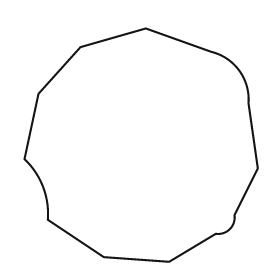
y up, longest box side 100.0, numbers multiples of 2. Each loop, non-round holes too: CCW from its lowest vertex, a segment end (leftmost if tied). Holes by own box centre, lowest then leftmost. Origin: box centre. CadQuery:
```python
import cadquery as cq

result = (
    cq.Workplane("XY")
    .moveTo(12.0, -50.0)
    .lineTo(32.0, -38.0)
    .threePointArc((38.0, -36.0), (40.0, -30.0))
    .lineTo(50.0, -10.0)
    .lineTo(46.0, 18.0)
    .threePointArc((42.0, 32.0), (30.0, 40.0))
    .lineTo(2.0, 50.0)
    .lineTo(-26.0, 42.0)
    .lineTo(-44.0, 22.0)
    .lineTo(-50.0, -6.0)
    .threePointArc((-42.0, -18.0), (-40.0, -32.0))
    .lineTo(-16.0, -48.0)
    .close()
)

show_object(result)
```